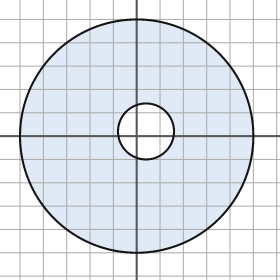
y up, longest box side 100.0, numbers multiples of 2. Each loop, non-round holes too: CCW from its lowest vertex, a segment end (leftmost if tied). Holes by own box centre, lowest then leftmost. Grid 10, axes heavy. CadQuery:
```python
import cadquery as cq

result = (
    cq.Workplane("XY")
    .moveTo(0.0, 0.0)
    .circle(50.0)
    .moveTo(4.0, 2.0)
    .circle(12.0)
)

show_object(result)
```